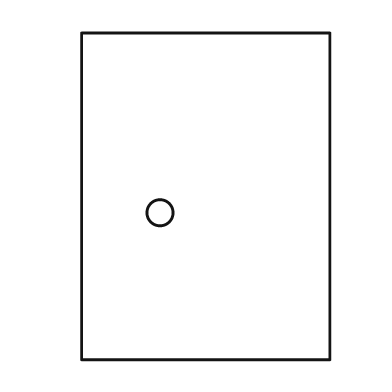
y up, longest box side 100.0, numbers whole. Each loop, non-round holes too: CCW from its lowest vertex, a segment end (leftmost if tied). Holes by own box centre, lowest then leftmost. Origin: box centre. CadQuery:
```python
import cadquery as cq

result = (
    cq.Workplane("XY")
    .moveTo(-38.0, -50.0)
    .lineTo(38.0, -50.0)
    .lineTo(38.0, 50.0)
    .lineTo(-38.0, 50.0)
    .close()
    .moveTo(-14.0, -5.0)
    .circle(4.0)
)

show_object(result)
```